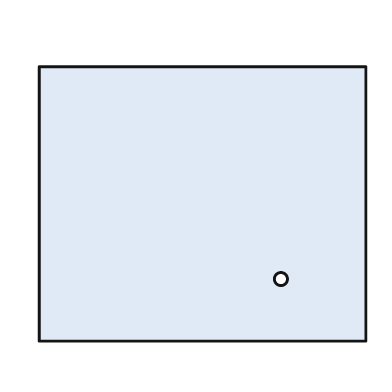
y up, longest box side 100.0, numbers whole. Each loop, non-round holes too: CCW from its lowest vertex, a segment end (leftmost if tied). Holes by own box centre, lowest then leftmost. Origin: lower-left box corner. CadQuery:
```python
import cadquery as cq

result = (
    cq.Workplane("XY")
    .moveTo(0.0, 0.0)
    .lineTo(100.0, 0.0)
    .lineTo(100.0, 84.0)
    .lineTo(0.0, 84.0)
    .close()
    .moveTo(74.0, 19.0)
    .circle(2.0)
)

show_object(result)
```